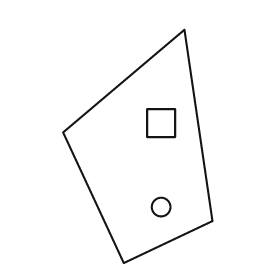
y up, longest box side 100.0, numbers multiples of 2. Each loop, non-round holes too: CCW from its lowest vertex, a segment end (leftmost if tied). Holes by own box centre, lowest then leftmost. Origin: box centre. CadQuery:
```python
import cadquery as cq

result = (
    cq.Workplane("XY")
    .moveTo(-6.0, -50.0)
    .lineTo(32.0, -32.0)
    .lineTo(20.0, 50.0)
    .lineTo(-32.0, 6.0)
    .close()
    .moveTo(10.0, -26.0)
    .circle(4.0)
    .moveTo(4.0, 4.0)
    .lineTo(16.0, 4.0)
    .lineTo(16.0, 16.0)
    .lineTo(4.0, 16.0)
    .close()
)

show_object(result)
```